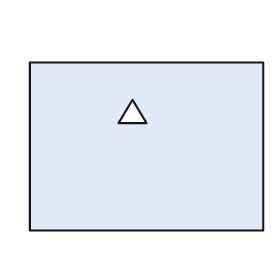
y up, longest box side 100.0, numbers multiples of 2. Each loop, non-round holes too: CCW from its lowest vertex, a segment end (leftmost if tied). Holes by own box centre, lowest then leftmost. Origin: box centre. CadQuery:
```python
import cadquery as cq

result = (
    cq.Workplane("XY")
    .moveTo(-50.0, -36.0)
    .lineTo(50.0, -36.0)
    .lineTo(50.0, 36.0)
    .lineTo(-50.0, 36.0)
    .close()
    .moveTo(-12.0, 10.0)
    .lineTo(0.0, 10.0)
    .lineTo(-6.0, 20.0)
    .close()
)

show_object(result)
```